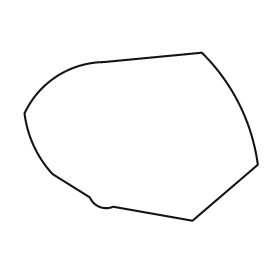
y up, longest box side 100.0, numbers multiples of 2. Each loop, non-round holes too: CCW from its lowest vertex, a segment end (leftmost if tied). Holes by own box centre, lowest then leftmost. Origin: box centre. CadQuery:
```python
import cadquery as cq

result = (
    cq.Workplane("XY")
    .moveTo(22.0, -36.0)
    .lineTo(50.0, -12.0)
    .threePointArc((42.0, 14.0), (26.0, 36.0))
    .lineTo(-16.0, 32.0)
    .threePointArc((-36.0, 26.0), (-50.0, 10.0))
    .threePointArc((-46.0, -4.0), (-38.0, -16.0))
    .lineTo(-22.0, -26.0)
    .threePointArc((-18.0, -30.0), (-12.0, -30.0))
    .close()
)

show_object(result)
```